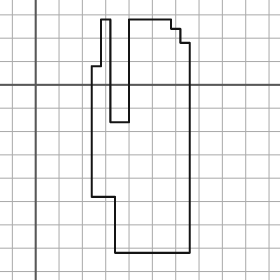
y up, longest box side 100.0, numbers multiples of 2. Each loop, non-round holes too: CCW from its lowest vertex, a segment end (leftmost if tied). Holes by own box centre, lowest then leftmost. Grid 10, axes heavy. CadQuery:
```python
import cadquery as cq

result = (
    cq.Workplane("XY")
    .moveTo(34.0, -72.0)
    .lineTo(66.0, -72.0)
    .lineTo(66.0, 18.0)
    .lineTo(62.0, 18.0)
    .lineTo(62.0, 24.0)
    .lineTo(58.0, 24.0)
    .lineTo(58.0, 28.0)
    .lineTo(40.0, 28.0)
    .lineTo(40.0, -16.0)
    .lineTo(32.0, -16.0)
    .lineTo(32.0, 28.0)
    .lineTo(28.0, 28.0)
    .lineTo(28.0, 8.0)
    .lineTo(24.0, 8.0)
    .lineTo(24.0, -48.0)
    .lineTo(34.0, -48.0)
    .close()
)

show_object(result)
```